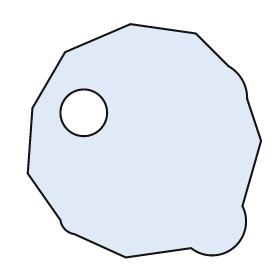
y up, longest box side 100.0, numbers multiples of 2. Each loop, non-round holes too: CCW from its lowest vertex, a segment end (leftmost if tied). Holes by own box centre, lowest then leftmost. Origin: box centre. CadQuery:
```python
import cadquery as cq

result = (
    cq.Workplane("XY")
    .moveTo(-8.0, -50.0)
    .lineTo(20.0, -46.0)
    .threePointArc((38.0, -46.0), (42.0, -28.0))
    .lineTo(50.0, 0.0)
    .lineTo(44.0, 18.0)
    .threePointArc((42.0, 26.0), (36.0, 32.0))
    .lineTo(22.0, 46.0)
    .lineTo(-6.0, 50.0)
    .lineTo(-34.0, 38.0)
    .lineTo(-48.0, 14.0)
    .lineTo(-50.0, -14.0)
    .lineTo(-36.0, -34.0)
    .threePointArc((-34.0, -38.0), (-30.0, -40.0))
    .close()
    .moveTo(-26.0, 12.0)
    .circle(10.0)
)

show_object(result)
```